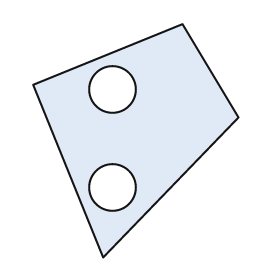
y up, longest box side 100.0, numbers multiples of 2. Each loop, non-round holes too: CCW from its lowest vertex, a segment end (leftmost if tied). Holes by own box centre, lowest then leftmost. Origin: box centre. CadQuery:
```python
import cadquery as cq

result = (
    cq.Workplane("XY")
    .moveTo(-14.0, -50.0)
    .lineTo(44.0, 10.0)
    .lineTo(20.0, 50.0)
    .lineTo(-44.0, 24.0)
    .close()
    .moveTo(-10.0, -20.0)
    .circle(10.0)
    .moveTo(-10.0, 22.0)
    .circle(10.0)
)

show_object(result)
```